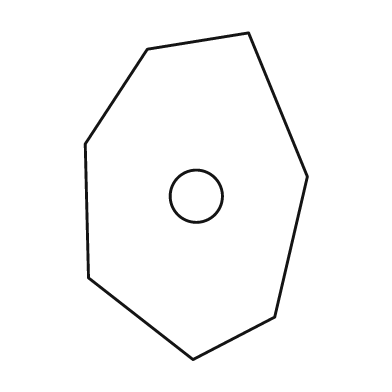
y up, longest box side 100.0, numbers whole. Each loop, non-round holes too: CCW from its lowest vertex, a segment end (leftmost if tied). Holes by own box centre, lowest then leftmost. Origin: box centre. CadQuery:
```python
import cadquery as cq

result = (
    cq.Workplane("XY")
    .moveTo(-1.0, -50.0)
    .lineTo(24.0, -37.0)
    .lineTo(34.0, 6.0)
    .lineTo(16.0, 50.0)
    .lineTo(-15.0, 45.0)
    .lineTo(-34.0, 16.0)
    .lineTo(-33.0, -25.0)
    .close()
    .moveTo(0.0, 0.0)
    .circle(8.0)
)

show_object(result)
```